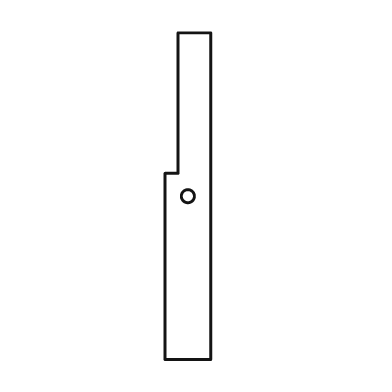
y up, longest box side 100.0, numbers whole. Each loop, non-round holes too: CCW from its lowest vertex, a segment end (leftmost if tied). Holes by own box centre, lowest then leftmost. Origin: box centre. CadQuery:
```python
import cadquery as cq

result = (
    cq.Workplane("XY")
    .moveTo(-7.0, -50.0)
    .lineTo(7.0, -50.0)
    .lineTo(7.0, 50.0)
    .lineTo(-3.0, 50.0)
    .lineTo(-3.0, 7.0)
    .lineTo(-7.0, 7.0)
    .close()
    .moveTo(0.0, 0.0)
    .circle(2.0)
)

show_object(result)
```